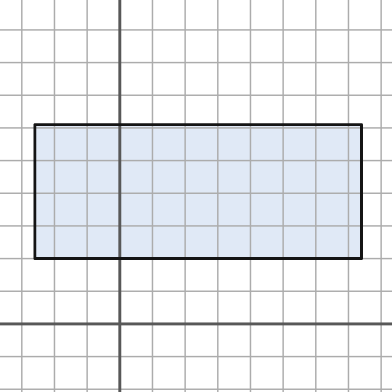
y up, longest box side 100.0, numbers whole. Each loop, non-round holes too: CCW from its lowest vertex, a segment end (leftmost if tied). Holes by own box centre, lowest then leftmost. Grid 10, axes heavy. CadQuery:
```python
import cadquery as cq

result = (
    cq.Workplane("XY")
    .moveTo(-26.0, 20.0)
    .lineTo(74.0, 20.0)
    .lineTo(74.0, 61.0)
    .lineTo(-26.0, 61.0)
    .close()
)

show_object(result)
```